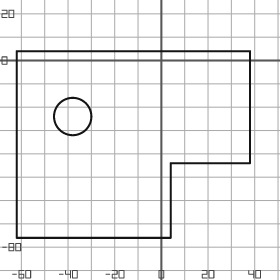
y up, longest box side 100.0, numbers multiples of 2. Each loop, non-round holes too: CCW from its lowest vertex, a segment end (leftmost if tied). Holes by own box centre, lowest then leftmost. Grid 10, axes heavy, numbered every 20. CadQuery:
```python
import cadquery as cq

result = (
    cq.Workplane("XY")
    .moveTo(-62.0, -76.0)
    .lineTo(4.0, -76.0)
    .lineTo(4.0, -44.0)
    .lineTo(38.0, -44.0)
    .lineTo(38.0, 4.0)
    .lineTo(-62.0, 4.0)
    .close()
    .moveTo(-38.0, -24.0)
    .circle(8.0)
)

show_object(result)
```